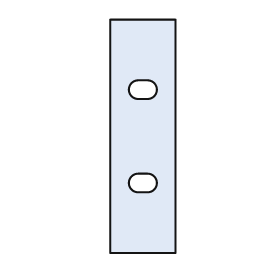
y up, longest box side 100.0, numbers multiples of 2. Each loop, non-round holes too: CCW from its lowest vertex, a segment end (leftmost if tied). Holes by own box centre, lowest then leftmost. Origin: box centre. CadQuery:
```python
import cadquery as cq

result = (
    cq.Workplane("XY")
    .moveTo(-14.0, -50.0)
    .lineTo(14.0, -50.0)
    .lineTo(14.0, 50.0)
    .lineTo(-14.0, 50.0)
    .close()
    .moveTo(-2.0, -24.0)
    .lineTo(2.0, -24.0)
    .threePointArc((6.0, -20.0), (2.0, -16.0))
    .lineTo(-2.0, -16.0)
    .threePointArc((-6.0, -20.0), (-2.0, -24.0))
    .close()
    .moveTo(-2.0, 16.0)
    .lineTo(2.0, 16.0)
    .threePointArc((6.0, 20.0), (2.0, 24.0))
    .lineTo(-2.0, 24.0)
    .threePointArc((-6.0, 20.0), (-2.0, 16.0))
    .close()
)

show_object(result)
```